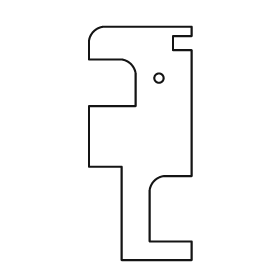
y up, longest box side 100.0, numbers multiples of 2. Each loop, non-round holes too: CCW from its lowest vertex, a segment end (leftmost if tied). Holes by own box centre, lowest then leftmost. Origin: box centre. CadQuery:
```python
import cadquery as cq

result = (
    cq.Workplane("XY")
    .moveTo(-8.0, -50.0)
    .lineTo(22.0, -50.0)
    .lineTo(22.0, -42.0)
    .lineTo(4.0, -42.0)
    .lineTo(4.0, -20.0)
    .threePointArc((6.0, -16.0), (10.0, -14.0))
    .lineTo(22.0, -14.0)
    .lineTo(22.0, 40.0)
    .lineTo(14.0, 40.0)
    .lineTo(14.0, 46.0)
    .lineTo(22.0, 46.0)
    .lineTo(22.0, 50.0)
    .lineTo(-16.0, 50.0)
    .threePointArc((-20.0, 48.0), (-22.0, 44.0))
    .lineTo(-22.0, 36.0)
    .lineTo(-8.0, 36.0)
    .threePointArc((-4.0, 34.0), (-2.0, 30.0))
    .lineTo(-2.0, 16.0)
    .lineTo(-22.0, 16.0)
    .lineTo(-22.0, -10.0)
    .lineTo(-8.0, -10.0)
    .close()
    .moveTo(8.0, 28.0)
    .circle(2.0)
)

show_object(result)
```